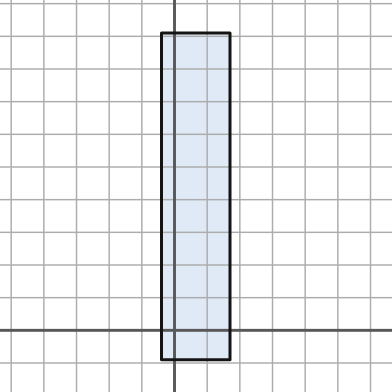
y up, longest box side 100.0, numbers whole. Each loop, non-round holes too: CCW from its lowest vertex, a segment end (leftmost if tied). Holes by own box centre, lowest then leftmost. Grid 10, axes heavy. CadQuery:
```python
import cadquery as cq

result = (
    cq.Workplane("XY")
    .moveTo(-4.0, -9.0)
    .lineTo(17.0, -9.0)
    .lineTo(17.0, 91.0)
    .lineTo(-4.0, 91.0)
    .close()
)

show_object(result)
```